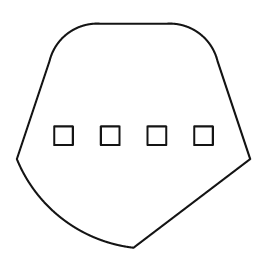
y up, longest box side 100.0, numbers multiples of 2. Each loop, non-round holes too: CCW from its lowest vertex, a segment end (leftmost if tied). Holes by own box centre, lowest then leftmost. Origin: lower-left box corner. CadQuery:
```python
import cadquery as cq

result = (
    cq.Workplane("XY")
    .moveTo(50.0, 0.0)
    .lineTo(100.0, 38.0)
    .lineTo(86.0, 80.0)
    .threePointArc((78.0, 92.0), (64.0, 96.0))
    .lineTo(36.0, 96.0)
    .threePointArc((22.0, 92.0), (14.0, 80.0))
    .lineTo(0.0, 38.0)
    .threePointArc((20.0, 12.0), (50.0, 0.0))
    .close()
    .moveTo(16.0, 44.0)
    .lineTo(24.0, 44.0)
    .lineTo(24.0, 52.0)
    .lineTo(16.0, 52.0)
    .close()
    .moveTo(36.0, 44.0)
    .lineTo(44.0, 44.0)
    .lineTo(44.0, 52.0)
    .lineTo(36.0, 52.0)
    .close()
    .moveTo(56.0, 44.0)
    .lineTo(64.0, 44.0)
    .lineTo(64.0, 52.0)
    .lineTo(56.0, 52.0)
    .close()
    .moveTo(76.0, 44.0)
    .lineTo(84.0, 44.0)
    .lineTo(84.0, 52.0)
    .lineTo(76.0, 52.0)
    .close()
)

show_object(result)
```